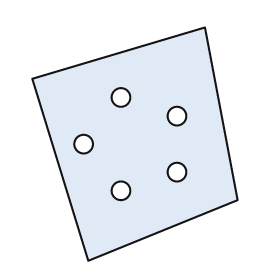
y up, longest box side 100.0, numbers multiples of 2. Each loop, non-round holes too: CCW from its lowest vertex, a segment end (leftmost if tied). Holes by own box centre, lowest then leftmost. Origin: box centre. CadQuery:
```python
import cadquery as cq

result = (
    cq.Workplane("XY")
    .moveTo(-20.0, -50.0)
    .lineTo(44.0, -24.0)
    .lineTo(30.0, 50.0)
    .lineTo(-44.0, 28.0)
    .close()
    .moveTo(-6.0, -20.0)
    .circle(4.0)
    .moveTo(18.0, -12.0)
    .circle(4.0)
    .moveTo(-22.0, 0.0)
    .circle(4.0)
    .moveTo(18.0, 12.0)
    .circle(4.0)
    .moveTo(-6.0, 20.0)
    .circle(4.0)
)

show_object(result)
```